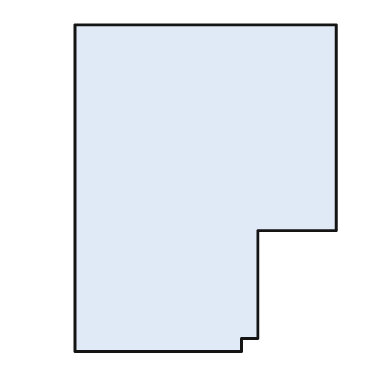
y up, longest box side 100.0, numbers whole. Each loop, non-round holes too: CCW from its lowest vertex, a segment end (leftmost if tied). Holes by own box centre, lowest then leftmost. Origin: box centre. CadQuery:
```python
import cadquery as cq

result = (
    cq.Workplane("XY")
    .moveTo(-40.0, -50.0)
    .lineTo(11.0, -50.0)
    .lineTo(11.0, -46.0)
    .lineTo(16.0, -46.0)
    .lineTo(16.0, -13.0)
    .lineTo(40.0, -13.0)
    .lineTo(40.0, 50.0)
    .lineTo(-40.0, 50.0)
    .close()
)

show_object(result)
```